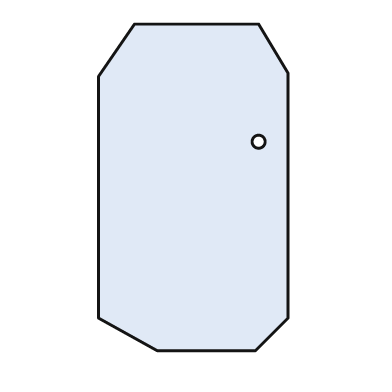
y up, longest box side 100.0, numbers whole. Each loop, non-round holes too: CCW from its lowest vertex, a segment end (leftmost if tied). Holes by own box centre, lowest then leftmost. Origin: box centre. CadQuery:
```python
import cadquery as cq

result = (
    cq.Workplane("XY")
    .moveTo(-11.0, -50.0)
    .lineTo(19.0, -50.0)
    .lineTo(29.0, -40.0)
    .lineTo(29.0, 35.0)
    .lineTo(20.0, 50.0)
    .lineTo(-18.0, 50.0)
    .lineTo(-29.0, 34.0)
    .lineTo(-29.0, -40.0)
    .close()
    .moveTo(20.0, 14.0)
    .circle(2.0)
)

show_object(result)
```